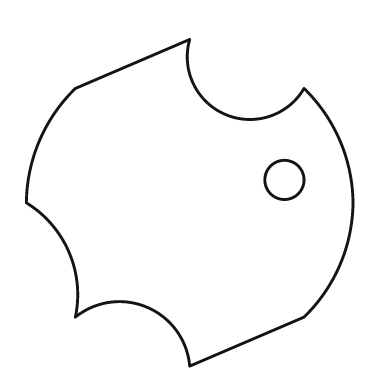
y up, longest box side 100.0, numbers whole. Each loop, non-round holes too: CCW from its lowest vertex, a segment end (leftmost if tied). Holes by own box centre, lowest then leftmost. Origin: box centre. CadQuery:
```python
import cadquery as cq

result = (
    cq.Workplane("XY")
    .moveTo(0.0, -50.0)
    .lineTo(35.0, -35.0)
    .threePointArc((46.0, -19.0), (50.0, 0.0))
    .threePointArc((46.0, 19.0), (35.0, 35.0))
    .threePointArc((11.0, 27.0), (0.0, 50.0))
    .lineTo(-35.0, 35.0)
    .threePointArc((-46.0, 19.0), (-50.0, 0.0))
    .threePointArc((-37.0, -15.0), (-35.0, -35.0))
    .threePointArc((-13.0, -32.0), (0.0, -50.0))
    .close()
    .moveTo(29.0, 7.0)
    .circle(6.0)
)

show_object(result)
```